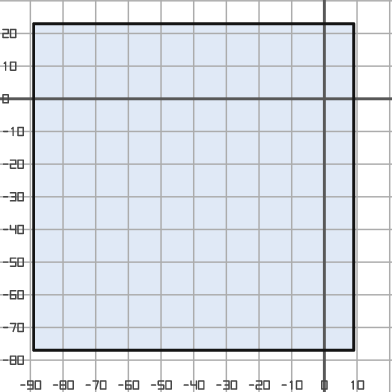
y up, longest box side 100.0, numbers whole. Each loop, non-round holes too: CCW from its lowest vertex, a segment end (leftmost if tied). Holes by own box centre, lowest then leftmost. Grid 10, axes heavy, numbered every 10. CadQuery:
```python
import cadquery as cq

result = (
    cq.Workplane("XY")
    .moveTo(-89.0, -77.0)
    .lineTo(9.0, -77.0)
    .lineTo(9.0, 23.0)
    .lineTo(-89.0, 23.0)
    .close()
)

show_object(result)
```